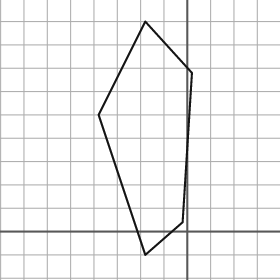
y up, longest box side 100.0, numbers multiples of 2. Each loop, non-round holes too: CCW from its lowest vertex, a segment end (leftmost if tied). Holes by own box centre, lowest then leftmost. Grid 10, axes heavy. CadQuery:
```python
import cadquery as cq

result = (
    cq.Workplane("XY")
    .moveTo(-18.0, -10.0)
    .lineTo(-2.0, 4.0)
    .lineTo(2.0, 68.0)
    .lineTo(-18.0, 90.0)
    .lineTo(-38.0, 50.0)
    .close()
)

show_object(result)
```